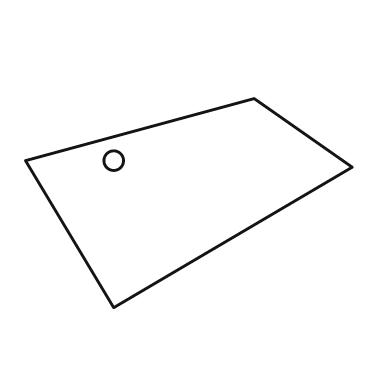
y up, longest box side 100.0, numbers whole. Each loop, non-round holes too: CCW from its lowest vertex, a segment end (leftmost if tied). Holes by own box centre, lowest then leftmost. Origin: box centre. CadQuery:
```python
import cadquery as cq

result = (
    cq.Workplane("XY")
    .moveTo(-23.0, -32.0)
    .lineTo(50.0, 11.0)
    .lineTo(20.0, 32.0)
    .lineTo(-50.0, 13.0)
    .close()
    .moveTo(-23.0, 13.0)
    .circle(3.0)
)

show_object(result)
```